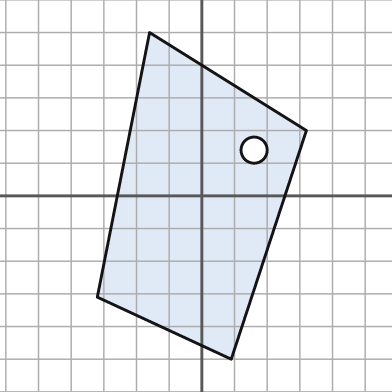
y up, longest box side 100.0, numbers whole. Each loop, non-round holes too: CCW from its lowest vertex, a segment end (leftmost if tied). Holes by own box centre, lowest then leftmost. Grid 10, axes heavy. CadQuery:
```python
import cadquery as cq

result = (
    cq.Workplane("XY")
    .moveTo(9.0, -50.0)
    .lineTo(32.0, 20.0)
    .lineTo(-16.0, 50.0)
    .lineTo(-32.0, -31.0)
    .close()
    .moveTo(16.0, 14.0)
    .circle(4.0)
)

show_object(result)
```